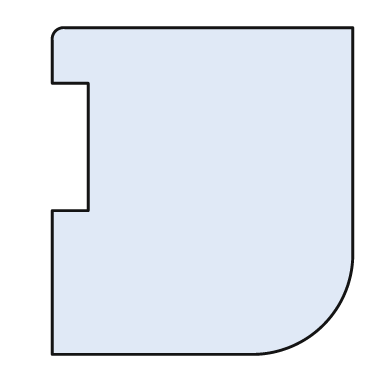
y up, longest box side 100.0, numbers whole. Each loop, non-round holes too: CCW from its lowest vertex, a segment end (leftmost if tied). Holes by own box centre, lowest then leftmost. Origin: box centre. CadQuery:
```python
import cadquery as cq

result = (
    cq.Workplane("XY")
    .moveTo(-46.0, -50.0)
    .lineTo(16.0, -50.0)
    .threePointArc((37.0, -41.0), (46.0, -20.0))
    .lineTo(46.0, 50.0)
    .lineTo(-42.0, 50.0)
    .threePointArc((-45.0, 49.0), (-46.0, 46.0))
    .lineTo(-46.0, 33.0)
    .lineTo(-35.0, 33.0)
    .lineTo(-35.0, -6.0)
    .lineTo(-46.0, -6.0)
    .close()
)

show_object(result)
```